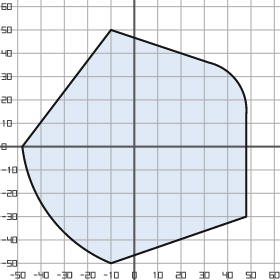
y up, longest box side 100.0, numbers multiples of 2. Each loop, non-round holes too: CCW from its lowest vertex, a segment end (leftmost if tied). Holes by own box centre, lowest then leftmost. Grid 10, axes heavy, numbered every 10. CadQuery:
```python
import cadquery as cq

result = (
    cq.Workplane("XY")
    .moveTo(-10.0, -50.0)
    .lineTo(48.0, -30.0)
    .lineTo(48.0, 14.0)
    .threePointArc((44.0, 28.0), (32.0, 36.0))
    .lineTo(-10.0, 50.0)
    .lineTo(-48.0, 0.0)
    .threePointArc((-36.0, -30.0), (-10.0, -50.0))
    .close()
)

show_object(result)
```